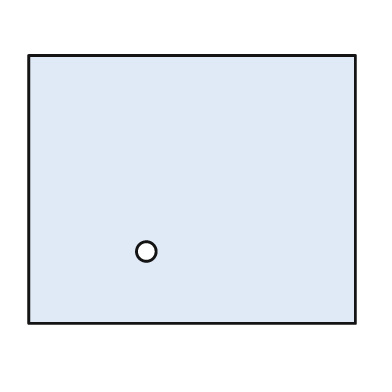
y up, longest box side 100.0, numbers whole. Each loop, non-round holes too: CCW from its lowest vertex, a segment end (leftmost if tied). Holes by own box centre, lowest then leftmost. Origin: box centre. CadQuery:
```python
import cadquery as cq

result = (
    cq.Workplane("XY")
    .moveTo(-50.0, -41.0)
    .lineTo(50.0, -41.0)
    .lineTo(50.0, 41.0)
    .lineTo(-50.0, 41.0)
    .close()
    .moveTo(-14.0, -19.0)
    .circle(3.0)
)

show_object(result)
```